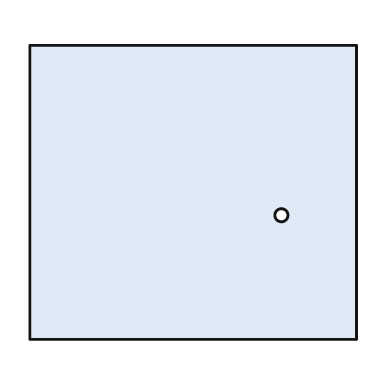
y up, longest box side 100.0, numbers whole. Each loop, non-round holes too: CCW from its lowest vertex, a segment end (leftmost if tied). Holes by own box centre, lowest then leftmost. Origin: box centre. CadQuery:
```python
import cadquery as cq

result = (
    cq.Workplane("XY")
    .moveTo(-50.0, -45.0)
    .lineTo(50.0, -45.0)
    .lineTo(50.0, 45.0)
    .lineTo(-50.0, 45.0)
    .close()
    .moveTo(27.0, -7.0)
    .circle(2.0)
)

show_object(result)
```